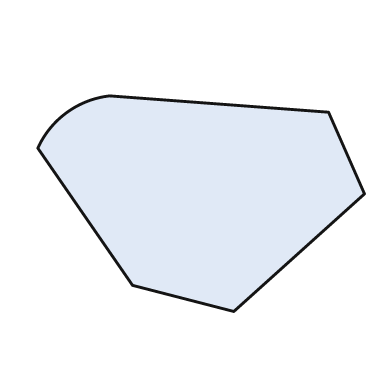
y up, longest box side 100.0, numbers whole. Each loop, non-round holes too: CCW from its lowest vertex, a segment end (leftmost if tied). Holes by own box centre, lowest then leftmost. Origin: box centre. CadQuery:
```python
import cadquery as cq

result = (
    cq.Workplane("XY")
    .moveTo(10.0, -33.0)
    .lineTo(50.0, 3.0)
    .lineTo(39.0, 28.0)
    .lineTo(-28.0, 33.0)
    .threePointArc((-41.0, 28.0), (-50.0, 17.0))
    .lineTo(-21.0, -25.0)
    .close()
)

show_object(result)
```